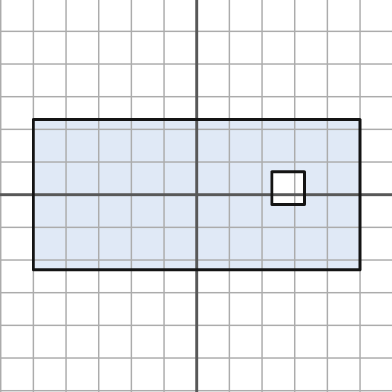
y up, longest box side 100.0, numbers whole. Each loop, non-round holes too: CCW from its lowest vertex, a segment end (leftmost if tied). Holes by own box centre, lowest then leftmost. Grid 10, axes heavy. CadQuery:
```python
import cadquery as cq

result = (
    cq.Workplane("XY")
    .moveTo(-50.0, -23.0)
    .lineTo(50.0, -23.0)
    .lineTo(50.0, 23.0)
    .lineTo(-50.0, 23.0)
    .close()
    .moveTo(23.0, -3.0)
    .lineTo(33.0, -3.0)
    .lineTo(33.0, 7.0)
    .lineTo(23.0, 7.0)
    .close()
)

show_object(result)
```